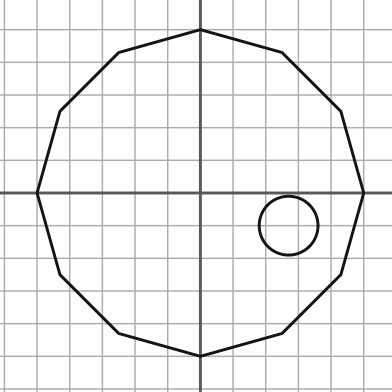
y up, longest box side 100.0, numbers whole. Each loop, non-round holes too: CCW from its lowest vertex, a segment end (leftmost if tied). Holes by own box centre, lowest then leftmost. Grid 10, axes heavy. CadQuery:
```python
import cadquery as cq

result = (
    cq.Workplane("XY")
    .moveTo(0.0, -50.0)
    .lineTo(25.0, -43.0)
    .lineTo(43.0, -25.0)
    .lineTo(50.0, 0.0)
    .lineTo(43.0, 25.0)
    .lineTo(25.0, 43.0)
    .lineTo(0.0, 50.0)
    .lineTo(-25.0, 43.0)
    .lineTo(-43.0, 25.0)
    .lineTo(-50.0, 0.0)
    .lineTo(-43.0, -25.0)
    .lineTo(-25.0, -43.0)
    .close()
    .moveTo(27.0, -10.0)
    .circle(9.0)
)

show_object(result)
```